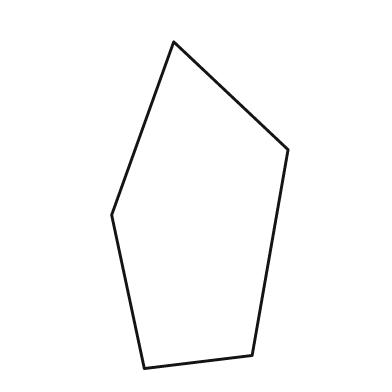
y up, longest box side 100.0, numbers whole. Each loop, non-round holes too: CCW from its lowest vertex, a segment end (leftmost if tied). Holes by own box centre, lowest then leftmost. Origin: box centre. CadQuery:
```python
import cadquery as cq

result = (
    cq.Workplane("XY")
    .moveTo(-17.0, -50.0)
    .lineTo(16.0, -46.0)
    .lineTo(27.0, 17.0)
    .lineTo(-8.0, 50.0)
    .lineTo(-27.0, -3.0)
    .close()
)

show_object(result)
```